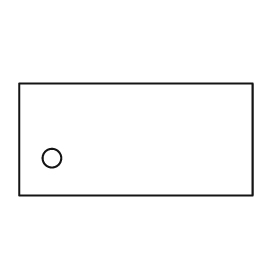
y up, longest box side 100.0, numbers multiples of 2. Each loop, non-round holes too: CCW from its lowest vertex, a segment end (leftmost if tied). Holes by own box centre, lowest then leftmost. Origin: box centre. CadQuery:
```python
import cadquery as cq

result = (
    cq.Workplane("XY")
    .moveTo(-50.0, -24.0)
    .lineTo(50.0, -24.0)
    .lineTo(50.0, 24.0)
    .lineTo(-50.0, 24.0)
    .close()
    .moveTo(-36.0, -8.0)
    .circle(4.0)
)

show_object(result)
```